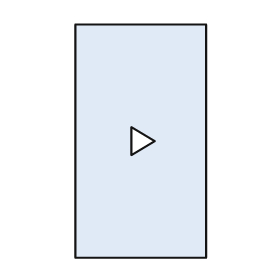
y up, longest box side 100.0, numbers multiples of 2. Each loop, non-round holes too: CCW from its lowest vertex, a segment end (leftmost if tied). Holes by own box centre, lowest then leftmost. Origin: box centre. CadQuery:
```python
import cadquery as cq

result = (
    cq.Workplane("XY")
    .moveTo(-28.0, -50.0)
    .lineTo(28.0, -50.0)
    .lineTo(28.0, 50.0)
    .lineTo(-28.0, 50.0)
    .close()
    .moveTo(-4.0, -6.0)
    .lineTo(6.0, 0.0)
    .lineTo(-4.0, 6.0)
    .close()
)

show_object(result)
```